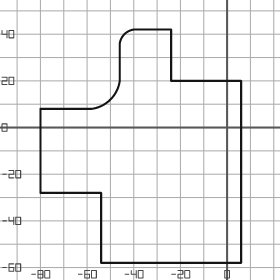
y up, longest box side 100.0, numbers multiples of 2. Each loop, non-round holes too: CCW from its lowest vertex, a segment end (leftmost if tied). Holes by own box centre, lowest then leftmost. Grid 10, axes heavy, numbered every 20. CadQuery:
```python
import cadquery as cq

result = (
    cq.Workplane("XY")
    .moveTo(-54.0, -58.0)
    .lineTo(6.0, -58.0)
    .lineTo(6.0, 20.0)
    .lineTo(-24.0, 20.0)
    .lineTo(-24.0, 42.0)
    .lineTo(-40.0, 42.0)
    .threePointArc((-44.0, 40.0), (-46.0, 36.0))
    .lineTo(-46.0, 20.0)
    .threePointArc((-50.0, 12.0), (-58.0, 8.0))
    .lineTo(-80.0, 8.0)
    .lineTo(-80.0, -28.0)
    .lineTo(-54.0, -28.0)
    .close()
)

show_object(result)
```